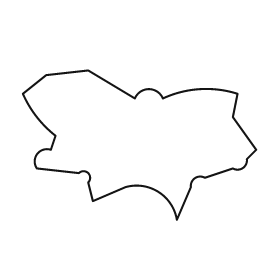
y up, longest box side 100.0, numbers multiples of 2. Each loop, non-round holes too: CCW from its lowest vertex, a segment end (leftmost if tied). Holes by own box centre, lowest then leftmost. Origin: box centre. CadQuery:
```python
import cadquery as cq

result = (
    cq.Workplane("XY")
    .moveTo(16.0, -32.0)
    .lineTo(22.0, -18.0)
    .threePointArc((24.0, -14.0), (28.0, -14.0))
    .lineTo(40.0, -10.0)
    .threePointArc((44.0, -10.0), (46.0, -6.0))
    .lineTo(50.0, -2.0)
    .lineTo(40.0, 12.0)
    .lineTo(42.0, 22.0)
    .threePointArc((26.0, 24.0), (10.0, 20.0))
    .threePointArc((4.0, 24.0), (-2.0, 20.0))
    .lineTo(-22.0, 32.0)
    .lineTo(-40.0, 30.0)
    .lineTo(-50.0, 22.0)
    .threePointArc((-44.0, 12.0), (-36.0, 4.0))
    .lineTo(-38.0, -2.0)
    .threePointArc((-44.0, -4.0), (-44.0, -10.0))
    .lineTo(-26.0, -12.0)
    .threePointArc((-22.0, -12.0), (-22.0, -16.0))
    .lineTo(-20.0, -24.0)
    .lineTo(-6.0, -18.0)
    .threePointArc((8.0, -20.0), (16.0, -32.0))
    .close()
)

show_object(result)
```